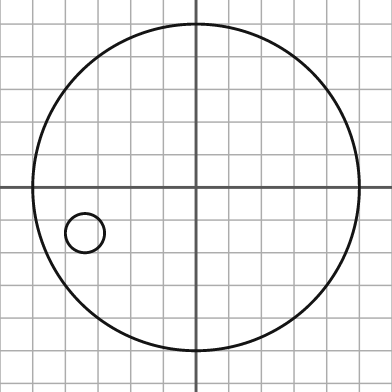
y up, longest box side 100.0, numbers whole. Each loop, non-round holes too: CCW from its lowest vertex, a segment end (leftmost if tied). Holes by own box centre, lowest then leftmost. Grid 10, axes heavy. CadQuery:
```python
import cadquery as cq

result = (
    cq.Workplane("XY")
    .moveTo(0.0, 0.0)
    .circle(50.0)
    .moveTo(-34.0, -14.0)
    .circle(6.0)
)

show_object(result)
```